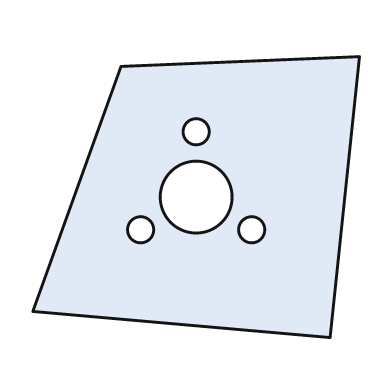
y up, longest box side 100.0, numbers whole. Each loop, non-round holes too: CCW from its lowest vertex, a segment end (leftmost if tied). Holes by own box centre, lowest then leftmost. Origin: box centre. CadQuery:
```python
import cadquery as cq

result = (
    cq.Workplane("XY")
    .moveTo(41.0, -43.0)
    .lineTo(50.0, 43.0)
    .lineTo(-23.0, 40.0)
    .lineTo(-50.0, -35.0)
    .close()
    .moveTo(-17.0, -10.0)
    .circle(4.0)
    .moveTo(17.0, -10.0)
    .circle(4.0)
    .moveTo(0.0, 0.0)
    .circle(11.0)
    .moveTo(0.0, 20.0)
    .circle(4.0)
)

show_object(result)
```